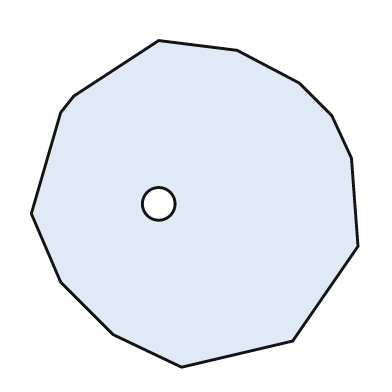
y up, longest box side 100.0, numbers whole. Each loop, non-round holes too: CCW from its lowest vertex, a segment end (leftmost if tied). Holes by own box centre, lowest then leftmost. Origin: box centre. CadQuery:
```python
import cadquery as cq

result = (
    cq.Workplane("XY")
    .moveTo(-4.0, -50.0)
    .lineTo(30.0, -42.0)
    .lineTo(50.0, -13.0)
    .lineTo(48.0, 14.0)
    .lineTo(42.0, 27.0)
    .lineTo(32.0, 37.0)
    .lineTo(13.0, 47.0)
    .lineTo(-11.0, 50.0)
    .lineTo(-37.0, 33.0)
    .lineTo(-41.0, 28.0)
    .lineTo(-50.0, -3.0)
    .lineTo(-41.0, -24.0)
    .lineTo(-25.0, -40.0)
    .close()
    .moveTo(-11.0, 0.0)
    .circle(5.0)
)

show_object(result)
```